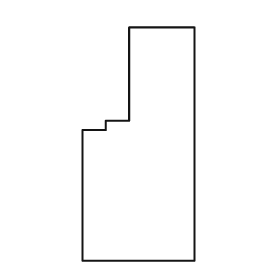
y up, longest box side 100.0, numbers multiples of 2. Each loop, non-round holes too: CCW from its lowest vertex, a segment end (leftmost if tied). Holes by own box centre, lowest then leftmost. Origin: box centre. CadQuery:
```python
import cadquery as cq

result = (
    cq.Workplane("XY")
    .moveTo(-24.0, -50.0)
    .lineTo(24.0, -50.0)
    .lineTo(24.0, 50.0)
    .lineTo(-4.0, 50.0)
    .lineTo(-4.0, 10.0)
    .lineTo(-14.0, 10.0)
    .lineTo(-14.0, 6.0)
    .lineTo(-24.0, 6.0)
    .close()
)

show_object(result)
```